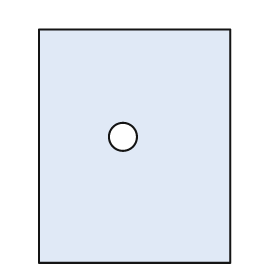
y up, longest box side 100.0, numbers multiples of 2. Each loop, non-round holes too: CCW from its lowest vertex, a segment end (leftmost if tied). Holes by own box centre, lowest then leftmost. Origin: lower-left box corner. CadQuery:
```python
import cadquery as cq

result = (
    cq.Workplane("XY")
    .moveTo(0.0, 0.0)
    .lineTo(82.0, 0.0)
    .lineTo(82.0, 100.0)
    .lineTo(0.0, 100.0)
    .close()
    .moveTo(36.0, 54.0)
    .circle(6.0)
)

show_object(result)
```